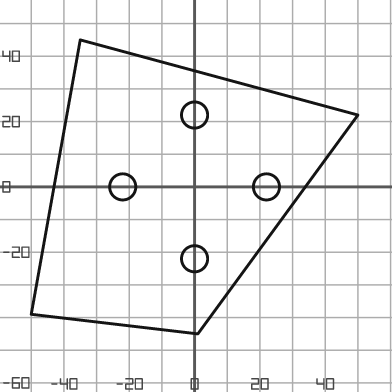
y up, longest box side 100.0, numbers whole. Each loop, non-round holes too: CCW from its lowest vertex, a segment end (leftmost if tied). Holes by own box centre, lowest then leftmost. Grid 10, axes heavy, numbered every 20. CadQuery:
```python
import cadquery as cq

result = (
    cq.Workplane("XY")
    .moveTo(1.0, -45.0)
    .lineTo(50.0, 22.0)
    .lineTo(-35.0, 45.0)
    .lineTo(-50.0, -39.0)
    .close()
    .moveTo(0.0, -22.0)
    .circle(4.0)
    .moveTo(-22.0, 0.0)
    .circle(4.0)
    .moveTo(22.0, 0.0)
    .circle(4.0)
    .moveTo(0.0, 22.0)
    .circle(4.0)
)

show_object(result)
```